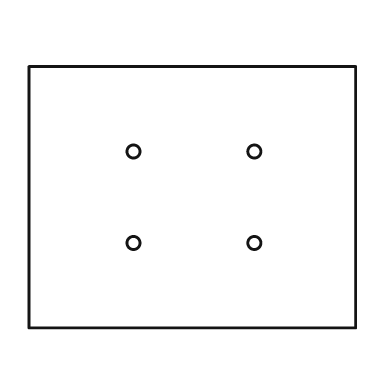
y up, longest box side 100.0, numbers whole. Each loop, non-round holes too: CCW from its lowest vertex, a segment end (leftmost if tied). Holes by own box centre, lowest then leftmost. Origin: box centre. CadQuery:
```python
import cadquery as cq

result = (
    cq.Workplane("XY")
    .moveTo(-50.0, -40.0)
    .lineTo(50.0, -40.0)
    .lineTo(50.0, 40.0)
    .lineTo(-50.0, 40.0)
    .close()
    .moveTo(-18.0, -14.0)
    .circle(2.0)
    .moveTo(19.0, -14.0)
    .circle(2.0)
    .moveTo(-18.0, 14.0)
    .circle(2.0)
    .moveTo(19.0, 14.0)
    .circle(2.0)
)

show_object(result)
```